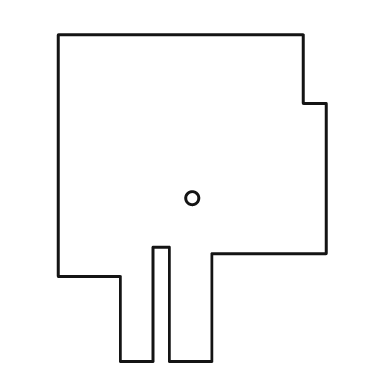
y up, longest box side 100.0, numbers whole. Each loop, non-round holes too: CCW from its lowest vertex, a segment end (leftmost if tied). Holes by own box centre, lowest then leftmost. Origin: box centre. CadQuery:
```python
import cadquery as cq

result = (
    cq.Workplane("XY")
    .moveTo(-22.0, -50.0)
    .lineTo(-12.0, -50.0)
    .lineTo(-12.0, -15.0)
    .lineTo(-7.0, -15.0)
    .lineTo(-7.0, -50.0)
    .lineTo(6.0, -50.0)
    .lineTo(6.0, -17.0)
    .lineTo(41.0, -17.0)
    .lineTo(41.0, 29.0)
    .lineTo(34.0, 29.0)
    .lineTo(34.0, 50.0)
    .lineTo(-41.0, 50.0)
    .lineTo(-41.0, -24.0)
    .lineTo(-22.0, -24.0)
    .close()
    .moveTo(0.0, 0.0)
    .circle(2.0)
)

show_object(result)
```